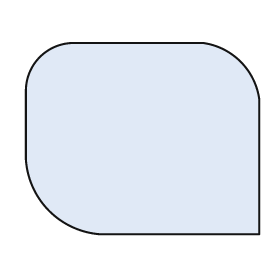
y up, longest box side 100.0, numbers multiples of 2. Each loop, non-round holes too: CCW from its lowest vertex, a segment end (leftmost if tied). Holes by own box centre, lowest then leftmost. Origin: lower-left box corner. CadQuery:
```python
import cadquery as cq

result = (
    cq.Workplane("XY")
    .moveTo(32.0, 0.0)
    .lineTo(100.0, 0.0)
    .lineTo(100.0, 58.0)
    .threePointArc((92.0, 74.0), (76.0, 82.0))
    .lineTo(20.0, 82.0)
    .threePointArc((6.0, 76.0), (0.0, 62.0))
    .lineTo(0.0, 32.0)
    .threePointArc((10.0, 10.0), (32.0, 0.0))
    .close()
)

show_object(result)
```